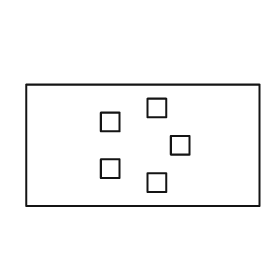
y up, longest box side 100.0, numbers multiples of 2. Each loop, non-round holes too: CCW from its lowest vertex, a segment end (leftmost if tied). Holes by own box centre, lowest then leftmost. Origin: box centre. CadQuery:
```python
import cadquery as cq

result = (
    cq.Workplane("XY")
    .moveTo(-50.0, -26.0)
    .lineTo(50.0, -26.0)
    .lineTo(50.0, 26.0)
    .lineTo(-50.0, 26.0)
    .close()
    .moveTo(2.0, -20.0)
    .lineTo(10.0, -20.0)
    .lineTo(10.0, -12.0)
    .lineTo(2.0, -12.0)
    .close()
    .moveTo(-18.0, -14.0)
    .lineTo(-10.0, -14.0)
    .lineTo(-10.0, -6.0)
    .lineTo(-18.0, -6.0)
    .close()
    .moveTo(12.0, -4.0)
    .lineTo(20.0, -4.0)
    .lineTo(20.0, 4.0)
    .lineTo(12.0, 4.0)
    .close()
    .moveTo(-18.0, 6.0)
    .lineTo(-10.0, 6.0)
    .lineTo(-10.0, 14.0)
    .lineTo(-18.0, 14.0)
    .close()
    .moveTo(2.0, 12.0)
    .lineTo(10.0, 12.0)
    .lineTo(10.0, 20.0)
    .lineTo(2.0, 20.0)
    .close()
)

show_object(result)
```